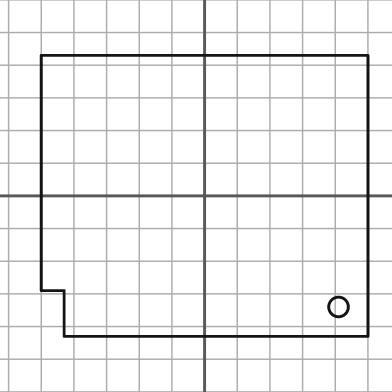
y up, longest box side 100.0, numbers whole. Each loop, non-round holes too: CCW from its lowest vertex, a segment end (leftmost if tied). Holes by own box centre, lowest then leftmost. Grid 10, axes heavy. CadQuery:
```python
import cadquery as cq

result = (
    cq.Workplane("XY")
    .moveTo(-43.0, -43.0)
    .lineTo(50.0, -43.0)
    .lineTo(50.0, 43.0)
    .lineTo(-50.0, 43.0)
    .lineTo(-50.0, -29.0)
    .lineTo(-43.0, -29.0)
    .close()
    .moveTo(41.0, -34.0)
    .circle(3.0)
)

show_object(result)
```